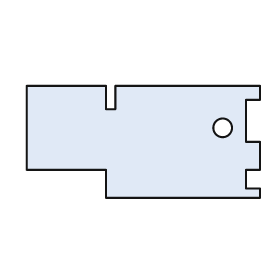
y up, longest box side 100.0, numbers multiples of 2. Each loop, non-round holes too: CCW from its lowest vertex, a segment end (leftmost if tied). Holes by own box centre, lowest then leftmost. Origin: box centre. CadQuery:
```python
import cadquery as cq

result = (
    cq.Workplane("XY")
    .moveTo(-16.0, -24.0)
    .lineTo(50.0, -24.0)
    .lineTo(50.0, -20.0)
    .lineTo(44.0, -20.0)
    .lineTo(44.0, -12.0)
    .lineTo(50.0, -12.0)
    .lineTo(50.0, 0.0)
    .lineTo(44.0, 0.0)
    .lineTo(44.0, 18.0)
    .lineTo(50.0, 18.0)
    .lineTo(50.0, 24.0)
    .lineTo(-12.0, 24.0)
    .lineTo(-12.0, 14.0)
    .lineTo(-16.0, 14.0)
    .lineTo(-16.0, 24.0)
    .lineTo(-50.0, 24.0)
    .lineTo(-50.0, -12.0)
    .lineTo(-16.0, -12.0)
    .close()
    .moveTo(34.0, 6.0)
    .circle(4.0)
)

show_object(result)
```